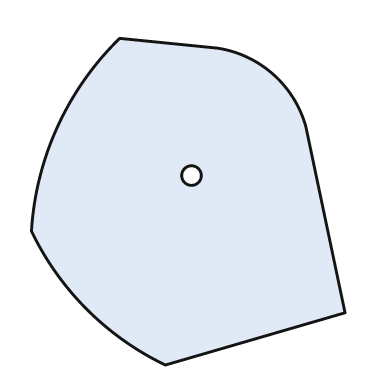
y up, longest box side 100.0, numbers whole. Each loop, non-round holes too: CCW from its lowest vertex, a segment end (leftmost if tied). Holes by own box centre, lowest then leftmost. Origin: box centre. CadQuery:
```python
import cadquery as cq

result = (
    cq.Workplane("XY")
    .moveTo(-7.0, -50.0)
    .lineTo(48.0, -34.0)
    .lineTo(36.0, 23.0)
    .threePointArc((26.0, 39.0), (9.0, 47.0))
    .lineTo(-21.0, 50.0)
    .threePointArc((-40.0, 23.0), (-48.0, -9.0))
    .threePointArc((-31.0, -33.0), (-7.0, -50.0))
    .close()
    .moveTo(1.0, 8.0)
    .circle(3.0)
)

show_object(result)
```